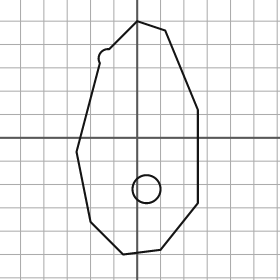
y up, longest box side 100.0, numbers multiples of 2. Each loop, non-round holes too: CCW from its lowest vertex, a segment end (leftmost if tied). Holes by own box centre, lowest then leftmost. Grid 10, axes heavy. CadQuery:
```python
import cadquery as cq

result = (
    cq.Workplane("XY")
    .moveTo(-6.0, -50.0)
    .lineTo(10.0, -48.0)
    .lineTo(26.0, -28.0)
    .lineTo(26.0, 12.0)
    .lineTo(12.0, 46.0)
    .lineTo(0.0, 50.0)
    .lineTo(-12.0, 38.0)
    .threePointArc((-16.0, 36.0), (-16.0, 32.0))
    .lineTo(-26.0, -6.0)
    .lineTo(-20.0, -36.0)
    .close()
    .moveTo(4.0, -22.0)
    .circle(6.0)
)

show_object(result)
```